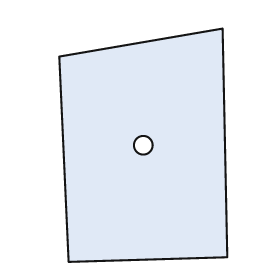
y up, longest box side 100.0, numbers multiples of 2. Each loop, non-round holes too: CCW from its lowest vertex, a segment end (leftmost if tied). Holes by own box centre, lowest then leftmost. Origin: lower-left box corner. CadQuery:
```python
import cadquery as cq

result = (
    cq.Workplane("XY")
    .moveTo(4.0, 0.0)
    .lineTo(72.0, 2.0)
    .lineTo(70.0, 100.0)
    .lineTo(0.0, 88.0)
    .close()
    .moveTo(36.0, 50.0)
    .circle(4.0)
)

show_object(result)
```